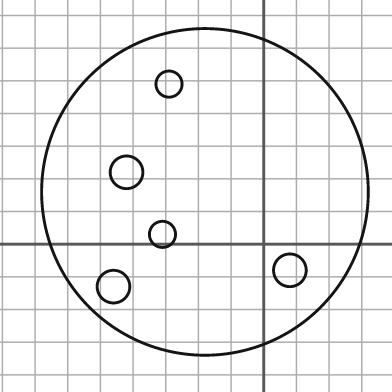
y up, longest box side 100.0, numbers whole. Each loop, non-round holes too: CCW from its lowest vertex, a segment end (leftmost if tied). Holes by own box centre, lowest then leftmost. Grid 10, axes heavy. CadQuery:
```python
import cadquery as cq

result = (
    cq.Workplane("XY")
    .moveTo(-18.0, 16.0)
    .circle(50.0)
    .moveTo(-46.0, -13.0)
    .circle(5.0)
    .moveTo(8.0, -8.0)
    .circle(5.0)
    .moveTo(-31.0, 3.0)
    .circle(4.0)
    .moveTo(-42.0, 22.0)
    .circle(5.0)
    .moveTo(-29.0, 49.0)
    .circle(4.0)
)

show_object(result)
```